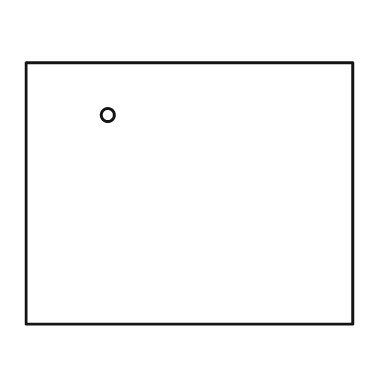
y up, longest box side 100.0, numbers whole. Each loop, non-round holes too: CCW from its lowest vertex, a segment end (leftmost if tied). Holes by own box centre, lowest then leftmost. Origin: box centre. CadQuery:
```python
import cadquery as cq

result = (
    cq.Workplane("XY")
    .moveTo(-50.0, -40.0)
    .lineTo(50.0, -40.0)
    .lineTo(50.0, 40.0)
    .lineTo(-50.0, 40.0)
    .close()
    .moveTo(-25.0, 24.0)
    .circle(2.0)
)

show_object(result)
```